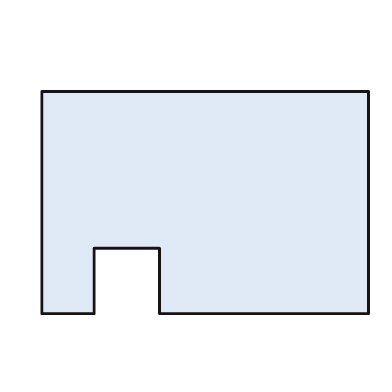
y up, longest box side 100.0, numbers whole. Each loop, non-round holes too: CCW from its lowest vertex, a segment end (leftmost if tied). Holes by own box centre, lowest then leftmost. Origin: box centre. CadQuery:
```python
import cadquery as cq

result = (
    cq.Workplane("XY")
    .moveTo(-50.0, -34.0)
    .lineTo(-34.0, -34.0)
    .lineTo(-34.0, -14.0)
    .lineTo(-14.0, -14.0)
    .lineTo(-14.0, -34.0)
    .lineTo(50.0, -34.0)
    .lineTo(50.0, 34.0)
    .lineTo(-50.0, 34.0)
    .close()
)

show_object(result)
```